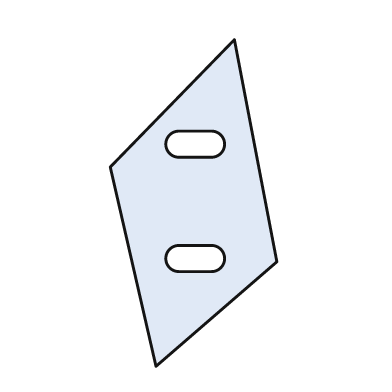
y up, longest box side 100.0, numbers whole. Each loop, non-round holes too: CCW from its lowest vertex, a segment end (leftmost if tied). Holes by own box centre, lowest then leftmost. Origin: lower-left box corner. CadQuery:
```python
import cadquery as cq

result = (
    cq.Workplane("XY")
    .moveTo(14.0, 0.0)
    .lineTo(51.0, 32.0)
    .lineTo(38.0, 100.0)
    .lineTo(0.0, 61.0)
    .close()
    .moveTo(21.0, 29.0)
    .lineTo(31.0, 29.0)
    .threePointArc((35.0, 33.0), (31.0, 37.0))
    .lineTo(21.0, 37.0)
    .threePointArc((17.0, 33.0), (21.0, 29.0))
    .close()
    .moveTo(21.0, 64.0)
    .lineTo(31.0, 64.0)
    .threePointArc((35.0, 68.0), (31.0, 72.0))
    .lineTo(21.0, 72.0)
    .threePointArc((17.0, 68.0), (21.0, 64.0))
    .close()
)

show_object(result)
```